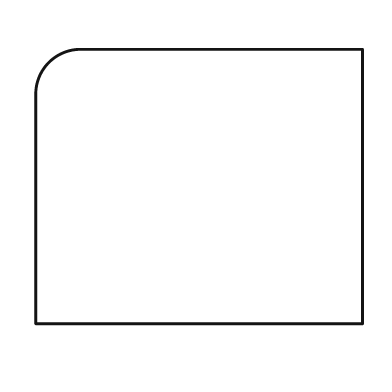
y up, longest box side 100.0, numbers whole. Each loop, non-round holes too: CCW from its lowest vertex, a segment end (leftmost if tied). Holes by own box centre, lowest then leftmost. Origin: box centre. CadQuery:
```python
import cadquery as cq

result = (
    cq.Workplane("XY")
    .moveTo(-50.0, -42.0)
    .lineTo(50.0, -42.0)
    .lineTo(50.0, 42.0)
    .lineTo(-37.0, 42.0)
    .threePointArc((-46.0, 38.0), (-50.0, 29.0))
    .close()
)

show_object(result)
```